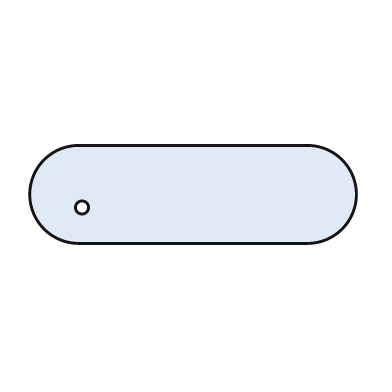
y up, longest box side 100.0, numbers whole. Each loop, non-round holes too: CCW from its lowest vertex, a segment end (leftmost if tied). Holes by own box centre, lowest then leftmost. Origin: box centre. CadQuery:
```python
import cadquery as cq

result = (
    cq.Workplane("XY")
    .moveTo(-35.0, -15.0)
    .lineTo(35.0, -15.0)
    .threePointArc((50.0, 0.0), (35.0, 15.0))
    .lineTo(-35.0, 15.0)
    .threePointArc((-50.0, 0.0), (-35.0, -15.0))
    .close()
    .moveTo(-34.0, -4.0)
    .circle(2.0)
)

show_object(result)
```